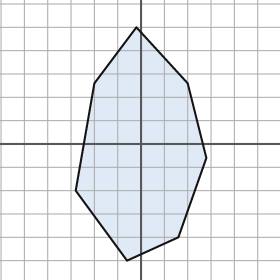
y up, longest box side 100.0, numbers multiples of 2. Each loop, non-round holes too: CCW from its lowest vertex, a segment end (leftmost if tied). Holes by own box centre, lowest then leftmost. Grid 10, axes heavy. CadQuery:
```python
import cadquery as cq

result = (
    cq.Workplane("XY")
    .moveTo(-6.0, -50.0)
    .lineTo(16.0, -40.0)
    .lineTo(28.0, -6.0)
    .lineTo(20.0, 26.0)
    .lineTo(-2.0, 50.0)
    .lineTo(-20.0, 26.0)
    .lineTo(-28.0, -20.0)
    .close()
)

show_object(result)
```